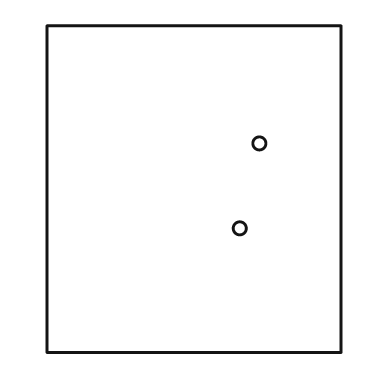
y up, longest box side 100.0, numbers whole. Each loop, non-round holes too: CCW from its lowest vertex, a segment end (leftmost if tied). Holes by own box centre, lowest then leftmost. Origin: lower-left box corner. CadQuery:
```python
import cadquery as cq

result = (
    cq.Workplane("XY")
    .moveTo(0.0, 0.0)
    .lineTo(90.0, 0.0)
    .lineTo(90.0, 100.0)
    .lineTo(0.0, 100.0)
    .close()
    .moveTo(59.0, 38.0)
    .circle(2.0)
    .moveTo(65.0, 64.0)
    .circle(2.0)
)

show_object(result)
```